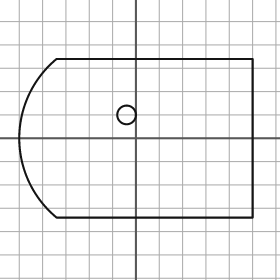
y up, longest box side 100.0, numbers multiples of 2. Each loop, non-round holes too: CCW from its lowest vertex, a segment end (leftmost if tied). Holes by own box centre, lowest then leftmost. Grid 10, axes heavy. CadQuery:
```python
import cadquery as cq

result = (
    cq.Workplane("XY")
    .moveTo(-34.0, -34.0)
    .lineTo(50.0, -34.0)
    .lineTo(50.0, 34.0)
    .lineTo(-34.0, 34.0)
    .threePointArc((-50.0, 0.0), (-34.0, -34.0))
    .close()
    .moveTo(-4.0, 10.0)
    .circle(4.0)
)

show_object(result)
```